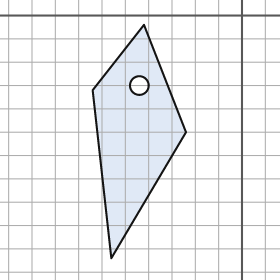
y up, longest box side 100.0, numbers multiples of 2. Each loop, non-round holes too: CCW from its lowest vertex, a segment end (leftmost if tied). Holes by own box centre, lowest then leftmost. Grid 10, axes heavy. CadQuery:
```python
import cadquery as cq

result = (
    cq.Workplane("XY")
    .moveTo(-56.0, -104.0)
    .lineTo(-24.0, -50.0)
    .lineTo(-42.0, -4.0)
    .lineTo(-64.0, -32.0)
    .close()
    .moveTo(-44.0, -30.0)
    .circle(4.0)
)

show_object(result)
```